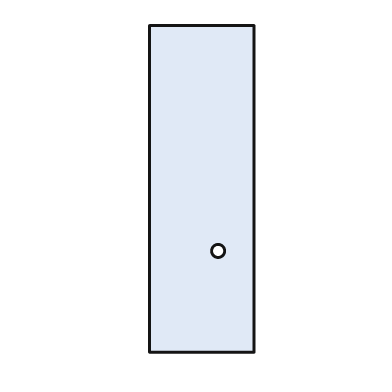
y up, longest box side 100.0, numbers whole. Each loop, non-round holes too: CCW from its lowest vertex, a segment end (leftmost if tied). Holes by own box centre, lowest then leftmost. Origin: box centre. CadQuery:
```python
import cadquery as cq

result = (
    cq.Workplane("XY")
    .moveTo(-16.0, -50.0)
    .lineTo(16.0, -50.0)
    .lineTo(16.0, 50.0)
    .lineTo(-16.0, 50.0)
    .close()
    .moveTo(5.0, -19.0)
    .circle(2.0)
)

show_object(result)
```